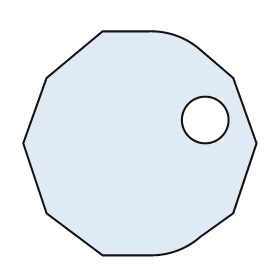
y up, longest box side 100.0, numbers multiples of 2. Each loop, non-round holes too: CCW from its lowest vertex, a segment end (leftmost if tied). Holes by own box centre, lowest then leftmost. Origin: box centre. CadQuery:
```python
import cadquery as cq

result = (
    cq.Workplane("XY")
    .moveTo(-16.0, -48.0)
    .lineTo(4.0, -48.0)
    .threePointArc((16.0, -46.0), (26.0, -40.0))
    .lineTo(40.0, -30.0)
    .lineTo(50.0, 0.0)
    .lineTo(40.0, 28.0)
    .lineTo(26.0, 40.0)
    .threePointArc((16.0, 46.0), (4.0, 48.0))
    .lineTo(-16.0, 48.0)
    .lineTo(-40.0, 28.0)
    .lineTo(-50.0, 0.0)
    .lineTo(-40.0, -30.0)
    .close()
    .moveTo(28.0, 10.0)
    .circle(10.0)
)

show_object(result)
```